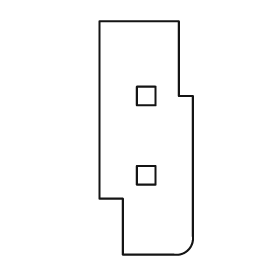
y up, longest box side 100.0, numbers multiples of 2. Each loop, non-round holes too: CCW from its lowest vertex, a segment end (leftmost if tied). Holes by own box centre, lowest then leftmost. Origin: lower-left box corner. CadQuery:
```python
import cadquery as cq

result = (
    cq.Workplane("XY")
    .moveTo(10.0, 0.0)
    .lineTo(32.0, 0.0)
    .threePointArc((38.0, 2.0), (40.0, 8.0))
    .lineTo(40.0, 68.0)
    .lineTo(34.0, 68.0)
    .lineTo(34.0, 100.0)
    .lineTo(0.0, 100.0)
    .lineTo(0.0, 24.0)
    .lineTo(10.0, 24.0)
    .close()
    .moveTo(16.0, 30.0)
    .lineTo(24.0, 30.0)
    .lineTo(24.0, 38.0)
    .lineTo(16.0, 38.0)
    .close()
    .moveTo(16.0, 64.0)
    .lineTo(24.0, 64.0)
    .lineTo(24.0, 72.0)
    .lineTo(16.0, 72.0)
    .close()
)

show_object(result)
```